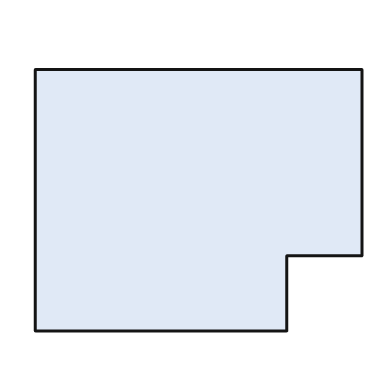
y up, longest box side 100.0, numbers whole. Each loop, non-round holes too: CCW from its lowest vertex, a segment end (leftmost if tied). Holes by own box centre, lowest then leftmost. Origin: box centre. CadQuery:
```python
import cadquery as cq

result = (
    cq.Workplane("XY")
    .moveTo(-50.0, -40.0)
    .lineTo(27.0, -40.0)
    .lineTo(27.0, -17.0)
    .lineTo(50.0, -17.0)
    .lineTo(50.0, 40.0)
    .lineTo(-50.0, 40.0)
    .close()
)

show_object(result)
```